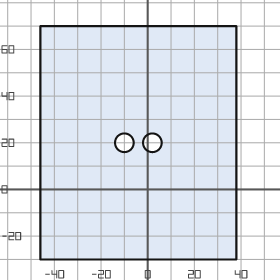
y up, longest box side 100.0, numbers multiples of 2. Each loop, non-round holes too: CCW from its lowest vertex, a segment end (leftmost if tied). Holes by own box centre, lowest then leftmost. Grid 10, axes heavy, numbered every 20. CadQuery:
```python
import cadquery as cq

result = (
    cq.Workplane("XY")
    .moveTo(-46.0, -30.0)
    .lineTo(38.0, -30.0)
    .lineTo(38.0, 70.0)
    .lineTo(-46.0, 70.0)
    .close()
    .moveTo(-10.0, 20.0)
    .circle(4.0)
    .moveTo(2.0, 20.0)
    .circle(4.0)
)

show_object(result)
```